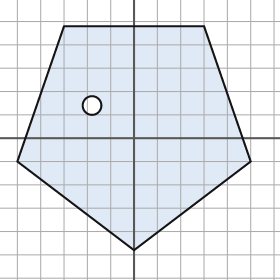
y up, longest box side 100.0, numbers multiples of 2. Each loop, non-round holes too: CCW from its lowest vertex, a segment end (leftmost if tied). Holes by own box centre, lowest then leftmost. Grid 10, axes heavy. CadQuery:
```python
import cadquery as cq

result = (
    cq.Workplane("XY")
    .moveTo(0.0, -48.0)
    .lineTo(50.0, -10.0)
    .lineTo(30.0, 48.0)
    .lineTo(-30.0, 48.0)
    .lineTo(-50.0, -10.0)
    .close()
    .moveTo(-18.0, 14.0)
    .circle(4.0)
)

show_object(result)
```